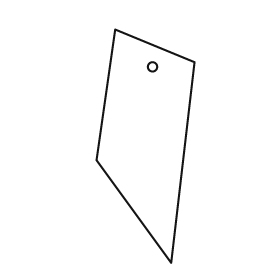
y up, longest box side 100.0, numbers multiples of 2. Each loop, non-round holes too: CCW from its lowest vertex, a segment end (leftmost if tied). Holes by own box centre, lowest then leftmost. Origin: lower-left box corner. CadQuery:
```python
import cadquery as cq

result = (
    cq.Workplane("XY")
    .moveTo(32.0, 0.0)
    .lineTo(42.0, 86.0)
    .lineTo(8.0, 100.0)
    .lineTo(0.0, 44.0)
    .close()
    .moveTo(24.0, 84.0)
    .circle(2.0)
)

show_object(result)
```